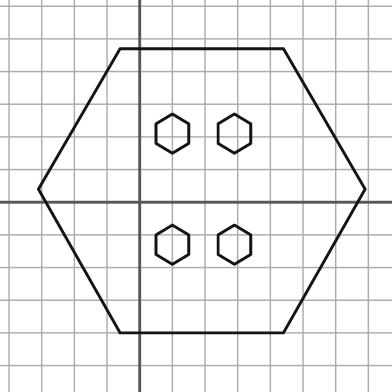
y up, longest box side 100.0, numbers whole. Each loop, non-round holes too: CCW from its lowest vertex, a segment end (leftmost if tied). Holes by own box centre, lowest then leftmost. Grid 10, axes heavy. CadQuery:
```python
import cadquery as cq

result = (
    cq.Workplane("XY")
    .moveTo(-6.0, -40.0)
    .lineTo(44.0, -40.0)
    .lineTo(69.0, 4.0)
    .lineTo(44.0, 47.0)
    .lineTo(-6.0, 47.0)
    .lineTo(-31.0, 4.0)
    .close()
    .moveTo(10.0, -19.0)
    .lineTo(15.0, -16.0)
    .lineTo(15.0, -10.0)
    .lineTo(10.0, -7.0)
    .lineTo(5.0, -10.0)
    .lineTo(5.0, -16.0)
    .close()
    .moveTo(29.0, -19.0)
    .lineTo(34.0, -16.0)
    .lineTo(34.0, -10.0)
    .lineTo(29.0, -7.0)
    .lineTo(24.0, -10.0)
    .lineTo(24.0, -16.0)
    .close()
    .moveTo(10.0, 15.0)
    .lineTo(15.0, 18.0)
    .lineTo(15.0, 24.0)
    .lineTo(10.0, 27.0)
    .lineTo(5.0, 24.0)
    .lineTo(5.0, 18.0)
    .close()
    .moveTo(29.0, 15.0)
    .lineTo(34.0, 18.0)
    .lineTo(34.0, 24.0)
    .lineTo(29.0, 27.0)
    .lineTo(24.0, 24.0)
    .lineTo(24.0, 18.0)
    .close()
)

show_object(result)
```